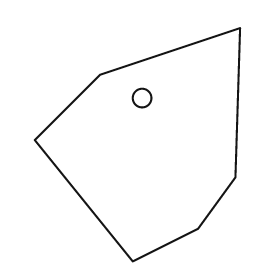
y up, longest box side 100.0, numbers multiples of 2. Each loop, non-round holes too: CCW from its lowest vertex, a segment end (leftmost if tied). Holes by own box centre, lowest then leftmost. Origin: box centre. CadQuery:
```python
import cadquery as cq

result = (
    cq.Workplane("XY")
    .moveTo(-2.0, -50.0)
    .lineTo(26.0, -36.0)
    .lineTo(42.0, -14.0)
    .lineTo(44.0, 50.0)
    .lineTo(-16.0, 30.0)
    .lineTo(-44.0, 2.0)
    .close()
    .moveTo(2.0, 20.0)
    .circle(4.0)
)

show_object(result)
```